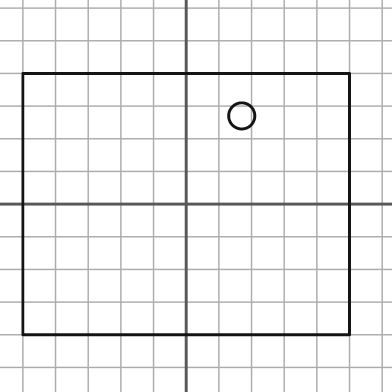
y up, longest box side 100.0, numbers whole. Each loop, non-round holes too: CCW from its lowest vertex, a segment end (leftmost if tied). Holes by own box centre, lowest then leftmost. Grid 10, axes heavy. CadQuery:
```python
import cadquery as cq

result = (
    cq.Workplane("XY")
    .moveTo(-50.0, -40.0)
    .lineTo(50.0, -40.0)
    .lineTo(50.0, 40.0)
    .lineTo(-50.0, 40.0)
    .close()
    .moveTo(17.0, 27.0)
    .circle(4.0)
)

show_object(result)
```